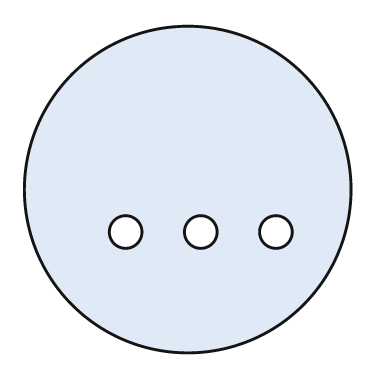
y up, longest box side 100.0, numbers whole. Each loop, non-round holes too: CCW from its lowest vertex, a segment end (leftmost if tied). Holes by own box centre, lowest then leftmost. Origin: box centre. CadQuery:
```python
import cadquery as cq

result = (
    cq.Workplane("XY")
    .moveTo(0.0, 0.0)
    .circle(50.0)
    .moveTo(-19.0, -13.0)
    .circle(5.0)
    .moveTo(4.0, -13.0)
    .circle(5.0)
    .moveTo(27.0, -13.0)
    .circle(5.0)
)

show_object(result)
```